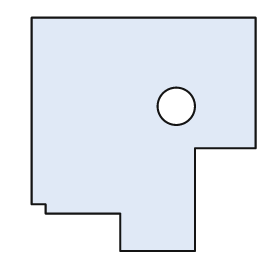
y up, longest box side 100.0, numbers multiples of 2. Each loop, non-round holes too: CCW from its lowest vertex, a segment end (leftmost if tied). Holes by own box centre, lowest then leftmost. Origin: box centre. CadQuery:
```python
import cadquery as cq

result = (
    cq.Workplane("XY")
    .moveTo(-10.0, -50.0)
    .lineTo(22.0, -50.0)
    .lineTo(22.0, -6.0)
    .lineTo(48.0, -6.0)
    .lineTo(48.0, 50.0)
    .lineTo(-48.0, 50.0)
    .lineTo(-48.0, -30.0)
    .lineTo(-42.0, -30.0)
    .lineTo(-42.0, -34.0)
    .lineTo(-10.0, -34.0)
    .close()
    .moveTo(14.0, 12.0)
    .circle(8.0)
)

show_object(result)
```